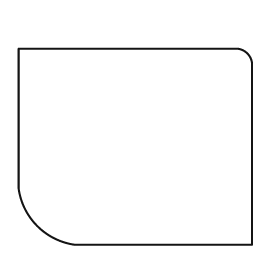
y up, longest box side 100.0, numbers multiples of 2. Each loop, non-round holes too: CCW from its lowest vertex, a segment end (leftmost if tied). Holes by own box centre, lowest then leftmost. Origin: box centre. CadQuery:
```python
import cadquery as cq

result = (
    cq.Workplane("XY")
    .moveTo(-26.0, -42.0)
    .lineTo(50.0, -42.0)
    .lineTo(50.0, 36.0)
    .threePointArc((48.0, 40.0), (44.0, 42.0))
    .lineTo(-50.0, 42.0)
    .lineTo(-50.0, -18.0)
    .threePointArc((-42.0, -34.0), (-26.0, -42.0))
    .close()
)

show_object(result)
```